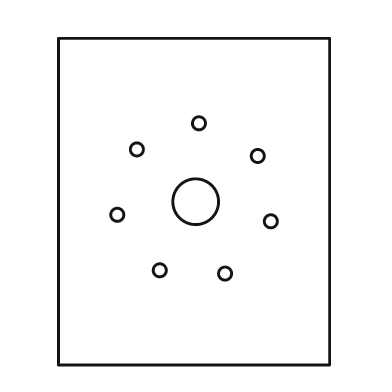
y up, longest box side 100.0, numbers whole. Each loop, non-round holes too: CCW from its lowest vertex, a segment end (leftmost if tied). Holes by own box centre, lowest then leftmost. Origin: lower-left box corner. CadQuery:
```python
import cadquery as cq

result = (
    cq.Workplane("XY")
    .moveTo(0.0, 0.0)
    .lineTo(83.0, 0.0)
    .lineTo(83.0, 100.0)
    .lineTo(0.0, 100.0)
    .close()
    .moveTo(51.0, 28.0)
    .circle(2.0)
    .moveTo(31.0, 29.0)
    .circle(2.0)
    .moveTo(65.0, 44.0)
    .circle(2.0)
    .moveTo(18.0, 46.0)
    .circle(2.0)
    .moveTo(42.0, 50.0)
    .circle(7.0)
    .moveTo(61.0, 64.0)
    .circle(2.0)
    .moveTo(24.0, 66.0)
    .circle(2.0)
    .moveTo(43.0, 74.0)
    .circle(2.0)
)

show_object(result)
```